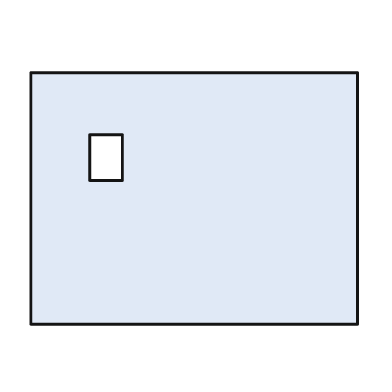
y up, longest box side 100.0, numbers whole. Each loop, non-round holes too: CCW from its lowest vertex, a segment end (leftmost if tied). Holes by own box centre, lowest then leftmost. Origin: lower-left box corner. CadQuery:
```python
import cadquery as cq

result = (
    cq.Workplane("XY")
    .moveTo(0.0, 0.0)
    .lineTo(100.0, 0.0)
    .lineTo(100.0, 77.0)
    .lineTo(0.0, 77.0)
    .close()
    .moveTo(18.0, 44.0)
    .lineTo(28.0, 44.0)
    .lineTo(28.0, 58.0)
    .lineTo(18.0, 58.0)
    .close()
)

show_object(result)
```